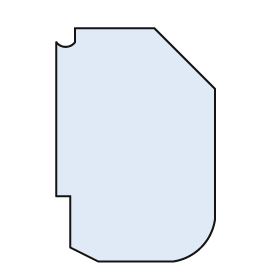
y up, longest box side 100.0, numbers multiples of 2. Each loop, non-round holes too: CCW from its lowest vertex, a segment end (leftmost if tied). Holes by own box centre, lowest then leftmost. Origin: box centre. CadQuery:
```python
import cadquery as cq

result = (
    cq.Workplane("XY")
    .moveTo(-16.0, -50.0)
    .lineTo(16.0, -50.0)
    .threePointArc((28.0, -44.0), (34.0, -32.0))
    .lineTo(34.0, 24.0)
    .lineTo(8.0, 50.0)
    .lineTo(-26.0, 50.0)
    .lineTo(-26.0, 44.0)
    .threePointArc((-30.0, 42.0), (-34.0, 44.0))
    .lineTo(-34.0, -22.0)
    .lineTo(-28.0, -22.0)
    .lineTo(-28.0, -44.0)
    .close()
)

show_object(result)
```